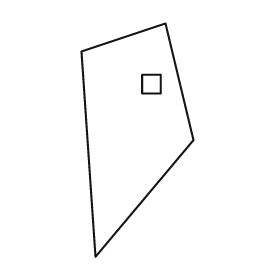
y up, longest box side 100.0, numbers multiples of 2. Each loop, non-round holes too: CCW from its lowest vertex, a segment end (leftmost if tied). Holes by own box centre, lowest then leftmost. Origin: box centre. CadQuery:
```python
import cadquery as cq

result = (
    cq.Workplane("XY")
    .moveTo(-18.0, -50.0)
    .lineTo(24.0, 0.0)
    .lineTo(12.0, 50.0)
    .lineTo(-24.0, 38.0)
    .close()
    .moveTo(2.0, 20.0)
    .lineTo(10.0, 20.0)
    .lineTo(10.0, 28.0)
    .lineTo(2.0, 28.0)
    .close()
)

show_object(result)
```